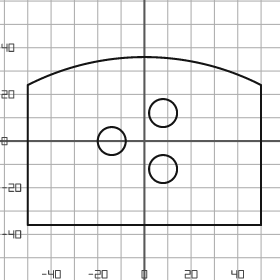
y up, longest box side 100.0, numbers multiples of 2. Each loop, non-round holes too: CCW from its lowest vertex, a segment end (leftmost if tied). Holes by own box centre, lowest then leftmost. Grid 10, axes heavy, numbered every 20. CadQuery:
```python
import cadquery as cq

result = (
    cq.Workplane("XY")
    .moveTo(-50.0, -36.0)
    .lineTo(50.0, -36.0)
    .lineTo(50.0, 24.0)
    .threePointArc((0.0, 36.0), (-50.0, 24.0))
    .close()
    .moveTo(8.0, -12.0)
    .circle(6.0)
    .moveTo(-14.0, 0.0)
    .circle(6.0)
    .moveTo(8.0, 12.0)
    .circle(6.0)
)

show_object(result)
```